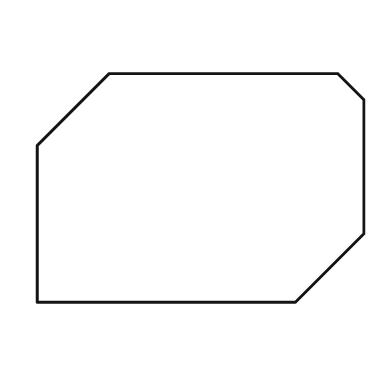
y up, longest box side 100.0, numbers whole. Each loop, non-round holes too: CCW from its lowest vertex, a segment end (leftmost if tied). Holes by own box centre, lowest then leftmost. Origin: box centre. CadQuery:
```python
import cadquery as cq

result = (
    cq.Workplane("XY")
    .moveTo(-50.0, -35.0)
    .lineTo(29.0, -35.0)
    .lineTo(50.0, -14.0)
    .lineTo(50.0, 27.0)
    .lineTo(42.0, 35.0)
    .lineTo(-28.0, 35.0)
    .lineTo(-50.0, 13.0)
    .close()
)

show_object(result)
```